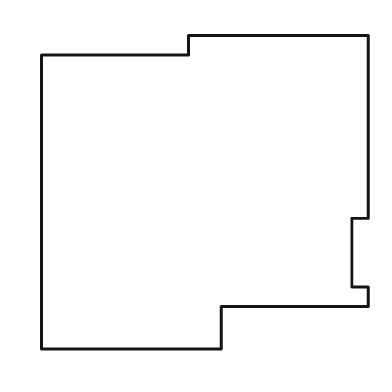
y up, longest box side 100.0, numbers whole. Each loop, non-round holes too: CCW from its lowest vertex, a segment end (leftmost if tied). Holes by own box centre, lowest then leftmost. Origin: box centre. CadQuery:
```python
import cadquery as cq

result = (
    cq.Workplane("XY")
    .moveTo(-50.0, -48.0)
    .lineTo(5.0, -48.0)
    .lineTo(5.0, -35.0)
    .lineTo(50.0, -35.0)
    .lineTo(50.0, -29.0)
    .lineTo(45.0, -29.0)
    .lineTo(45.0, -8.0)
    .lineTo(50.0, -8.0)
    .lineTo(50.0, 48.0)
    .lineTo(-5.0, 48.0)
    .lineTo(-5.0, 42.0)
    .lineTo(-50.0, 42.0)
    .close()
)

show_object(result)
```